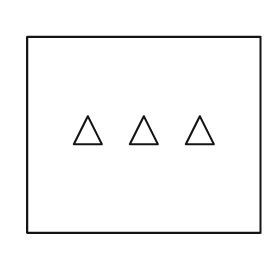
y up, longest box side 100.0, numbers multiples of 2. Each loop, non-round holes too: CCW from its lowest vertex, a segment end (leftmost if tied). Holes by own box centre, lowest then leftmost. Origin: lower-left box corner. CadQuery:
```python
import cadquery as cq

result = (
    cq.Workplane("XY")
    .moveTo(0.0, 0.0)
    .lineTo(100.0, 0.0)
    .lineTo(100.0, 84.0)
    .lineTo(0.0, 84.0)
    .close()
    .moveTo(20.0, 38.0)
    .lineTo(32.0, 38.0)
    .lineTo(26.0, 50.0)
    .close()
    .moveTo(44.0, 38.0)
    .lineTo(56.0, 38.0)
    .lineTo(50.0, 50.0)
    .close()
    .moveTo(68.0, 38.0)
    .lineTo(80.0, 38.0)
    .lineTo(74.0, 50.0)
    .close()
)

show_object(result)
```